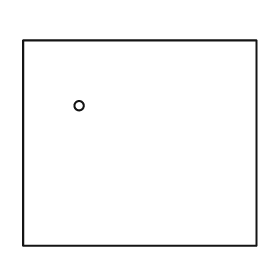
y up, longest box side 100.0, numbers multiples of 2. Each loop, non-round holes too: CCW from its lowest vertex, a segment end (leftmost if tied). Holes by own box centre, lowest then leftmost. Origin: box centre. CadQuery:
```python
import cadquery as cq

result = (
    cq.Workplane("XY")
    .moveTo(-50.0, -44.0)
    .lineTo(50.0, -44.0)
    .lineTo(50.0, 44.0)
    .lineTo(-50.0, 44.0)
    .close()
    .moveTo(-26.0, 16.0)
    .circle(2.0)
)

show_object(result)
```